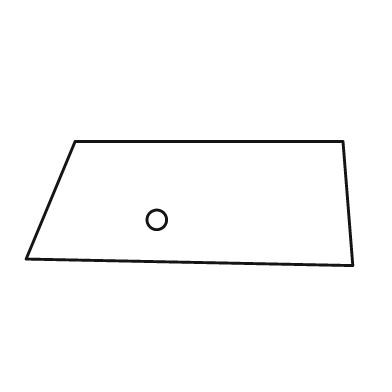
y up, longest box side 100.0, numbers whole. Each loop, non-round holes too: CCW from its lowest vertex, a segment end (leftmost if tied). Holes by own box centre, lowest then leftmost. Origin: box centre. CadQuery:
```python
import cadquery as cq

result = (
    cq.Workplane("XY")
    .moveTo(50.0, -19.0)
    .lineTo(47.0, 19.0)
    .lineTo(-35.0, 19.0)
    .lineTo(-50.0, -17.0)
    .close()
    .moveTo(-10.0, -5.0)
    .circle(3.0)
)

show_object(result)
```